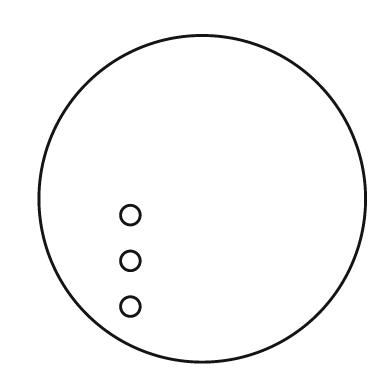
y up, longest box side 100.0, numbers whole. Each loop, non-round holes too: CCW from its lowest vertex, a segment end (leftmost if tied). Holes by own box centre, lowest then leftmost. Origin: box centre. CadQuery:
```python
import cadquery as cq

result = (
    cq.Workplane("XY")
    .moveTo(0.0, 0.0)
    .circle(50.0)
    .moveTo(-22.0, -33.0)
    .circle(3.0)
    .moveTo(-22.0, -19.0)
    .circle(3.0)
    .moveTo(-22.0, -5.0)
    .circle(3.0)
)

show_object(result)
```